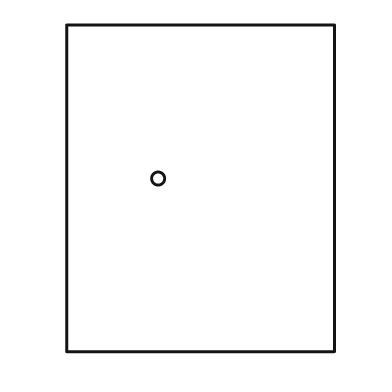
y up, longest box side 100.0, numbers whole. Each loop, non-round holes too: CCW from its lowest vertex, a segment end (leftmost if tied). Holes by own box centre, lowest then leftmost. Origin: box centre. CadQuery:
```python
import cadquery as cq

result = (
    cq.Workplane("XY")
    .moveTo(-41.0, -50.0)
    .lineTo(41.0, -50.0)
    .lineTo(41.0, 50.0)
    .lineTo(-41.0, 50.0)
    .close()
    .moveTo(-13.0, 3.0)
    .circle(2.0)
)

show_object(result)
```